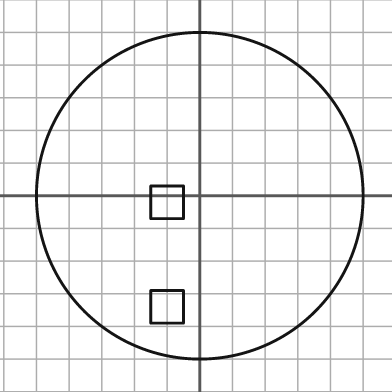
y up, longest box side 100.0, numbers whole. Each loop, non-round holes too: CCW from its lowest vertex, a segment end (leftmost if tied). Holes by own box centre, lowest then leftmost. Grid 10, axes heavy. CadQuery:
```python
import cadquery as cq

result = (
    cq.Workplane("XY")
    .moveTo(0.0, 0.0)
    .circle(50.0)
    .moveTo(-15.0, -39.0)
    .lineTo(-5.0, -39.0)
    .lineTo(-5.0, -29.0)
    .lineTo(-15.0, -29.0)
    .close()
    .moveTo(-15.0, -7.0)
    .lineTo(-5.0, -7.0)
    .lineTo(-5.0, 3.0)
    .lineTo(-15.0, 3.0)
    .close()
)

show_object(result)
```